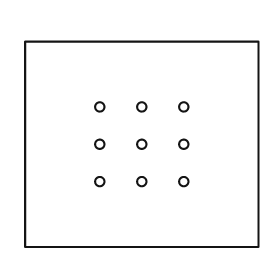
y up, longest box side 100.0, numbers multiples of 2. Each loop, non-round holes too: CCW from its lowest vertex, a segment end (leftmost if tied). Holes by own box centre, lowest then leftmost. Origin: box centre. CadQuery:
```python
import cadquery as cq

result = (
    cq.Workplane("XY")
    .moveTo(-50.0, -44.0)
    .lineTo(50.0, -44.0)
    .lineTo(50.0, 44.0)
    .lineTo(-50.0, 44.0)
    .close()
    .moveTo(-18.0, -16.0)
    .circle(2.0)
    .moveTo(0.0, -16.0)
    .circle(2.0)
    .moveTo(18.0, -16.0)
    .circle(2.0)
    .moveTo(-18.0, 0.0)
    .circle(2.0)
    .moveTo(0.0, 0.0)
    .circle(2.0)
    .moveTo(18.0, 0.0)
    .circle(2.0)
    .moveTo(-18.0, 16.0)
    .circle(2.0)
    .moveTo(0.0, 16.0)
    .circle(2.0)
    .moveTo(18.0, 16.0)
    .circle(2.0)
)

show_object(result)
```